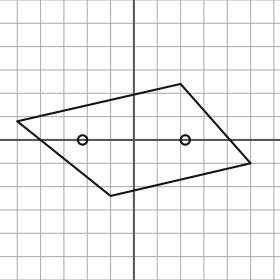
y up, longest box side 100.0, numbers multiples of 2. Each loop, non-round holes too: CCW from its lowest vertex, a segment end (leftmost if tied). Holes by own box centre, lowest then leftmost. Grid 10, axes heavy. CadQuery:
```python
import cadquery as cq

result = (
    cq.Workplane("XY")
    .moveTo(-10.0, -24.0)
    .lineTo(50.0, -10.0)
    .lineTo(20.0, 24.0)
    .lineTo(-50.0, 8.0)
    .close()
    .moveTo(-22.0, 0.0)
    .circle(2.0)
    .moveTo(22.0, 0.0)
    .circle(2.0)
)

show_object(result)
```